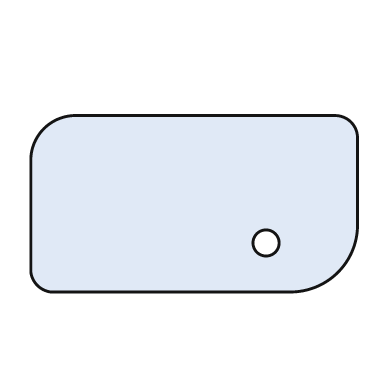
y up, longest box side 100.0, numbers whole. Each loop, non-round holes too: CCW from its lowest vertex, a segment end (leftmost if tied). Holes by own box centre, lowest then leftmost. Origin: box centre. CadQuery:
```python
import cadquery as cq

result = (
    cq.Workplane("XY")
    .moveTo(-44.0, -27.0)
    .lineTo(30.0, -27.0)
    .threePointArc((44.0, -21.0), (50.0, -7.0))
    .lineTo(50.0, 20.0)
    .threePointArc((48.0, 25.0), (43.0, 27.0))
    .lineTo(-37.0, 27.0)
    .threePointArc((-46.0, 23.0), (-50.0, 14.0))
    .lineTo(-50.0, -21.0)
    .threePointArc((-48.0, -25.0), (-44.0, -27.0))
    .close()
    .moveTo(22.0, -12.0)
    .circle(4.0)
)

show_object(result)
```